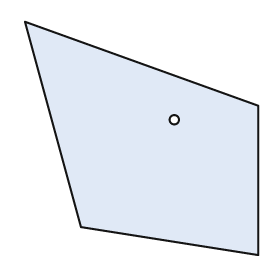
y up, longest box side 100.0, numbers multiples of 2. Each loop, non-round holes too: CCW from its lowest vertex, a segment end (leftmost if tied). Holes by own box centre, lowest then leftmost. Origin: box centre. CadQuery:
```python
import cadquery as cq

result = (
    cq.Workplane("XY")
    .moveTo(50.0, -50.0)
    .lineTo(50.0, 14.0)
    .lineTo(-50.0, 50.0)
    .lineTo(-26.0, -38.0)
    .close()
    .moveTo(14.0, 8.0)
    .circle(2.0)
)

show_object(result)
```